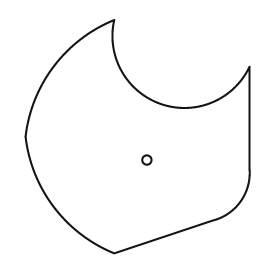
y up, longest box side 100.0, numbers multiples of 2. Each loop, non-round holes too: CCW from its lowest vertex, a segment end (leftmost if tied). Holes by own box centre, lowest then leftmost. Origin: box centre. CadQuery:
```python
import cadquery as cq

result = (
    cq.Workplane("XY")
    .moveTo(-10.0, -50.0)
    .lineTo(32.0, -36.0)
    .threePointArc((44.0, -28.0), (48.0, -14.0))
    .lineTo(48.0, 30.0)
    .threePointArc((10.0, 14.0), (-10.0, 50.0))
    .threePointArc((-36.0, 30.0), (-48.0, 0.0))
    .threePointArc((-36.0, -30.0), (-10.0, -50.0))
    .close()
    .moveTo(4.0, -10.0)
    .circle(2.0)
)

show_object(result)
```